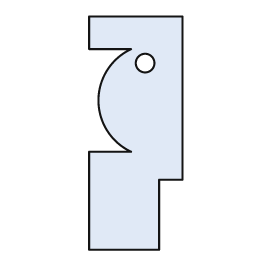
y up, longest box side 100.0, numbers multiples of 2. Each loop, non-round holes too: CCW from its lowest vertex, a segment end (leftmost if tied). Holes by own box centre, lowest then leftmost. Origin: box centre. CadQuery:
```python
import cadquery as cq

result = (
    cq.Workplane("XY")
    .moveTo(-20.0, -50.0)
    .lineTo(10.0, -50.0)
    .lineTo(10.0, -20.0)
    .lineTo(20.0, -20.0)
    .lineTo(20.0, 50.0)
    .lineTo(-20.0, 50.0)
    .lineTo(-20.0, 36.0)
    .lineTo(-2.0, 36.0)
    .threePointArc((-16.0, 14.0), (-2.0, -8.0))
    .lineTo(-20.0, -8.0)
    .close()
    .moveTo(4.0, 30.0)
    .circle(4.0)
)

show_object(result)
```